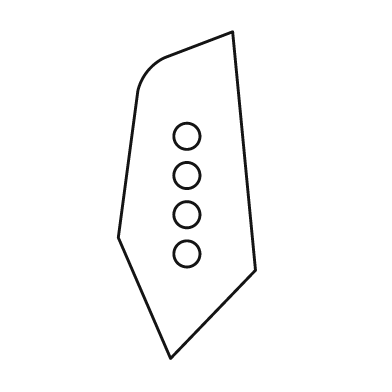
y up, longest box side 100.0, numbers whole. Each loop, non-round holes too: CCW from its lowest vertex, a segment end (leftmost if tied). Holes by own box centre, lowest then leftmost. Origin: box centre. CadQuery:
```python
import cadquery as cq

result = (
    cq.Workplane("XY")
    .moveTo(-5.0, -50.0)
    .lineTo(21.0, -23.0)
    .lineTo(14.0, 50.0)
    .lineTo(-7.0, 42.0)
    .threePointArc((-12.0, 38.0), (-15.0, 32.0))
    .lineTo(-21.0, -13.0)
    .close()
    .moveTo(0.0, -18.0)
    .circle(4.0)
    .moveTo(0.0, -6.0)
    .circle(4.0)
    .moveTo(0.0, 6.0)
    .circle(4.0)
    .moveTo(0.0, 18.0)
    .circle(4.0)
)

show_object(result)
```